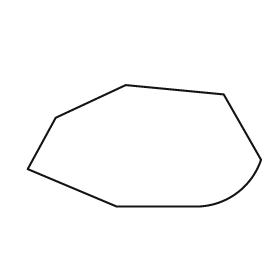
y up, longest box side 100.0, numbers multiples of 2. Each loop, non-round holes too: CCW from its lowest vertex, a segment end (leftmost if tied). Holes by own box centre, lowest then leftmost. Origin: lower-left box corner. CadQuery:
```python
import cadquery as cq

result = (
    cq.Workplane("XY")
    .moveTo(38.0, 0.0)
    .lineTo(74.0, 0.0)
    .threePointArc((90.0, 6.0), (100.0, 20.0))
    .lineTo(84.0, 48.0)
    .lineTo(42.0, 52.0)
    .lineTo(12.0, 38.0)
    .lineTo(0.0, 16.0)
    .close()
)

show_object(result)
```